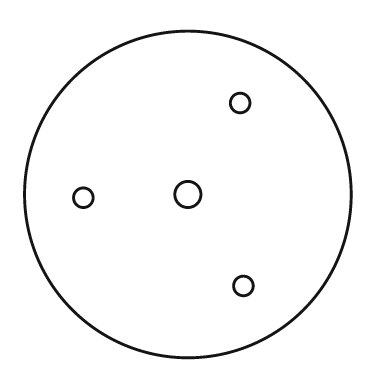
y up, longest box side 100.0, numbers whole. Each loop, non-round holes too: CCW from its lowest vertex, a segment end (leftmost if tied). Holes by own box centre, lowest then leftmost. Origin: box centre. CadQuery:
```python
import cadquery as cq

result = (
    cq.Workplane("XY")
    .moveTo(0.0, 0.0)
    .circle(50.0)
    .moveTo(17.0, -28.0)
    .circle(3.0)
    .moveTo(-32.0, -1.0)
    .circle(3.0)
    .moveTo(0.0, 0.0)
    .circle(4.0)
    .moveTo(16.0, 28.0)
    .circle(3.0)
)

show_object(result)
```